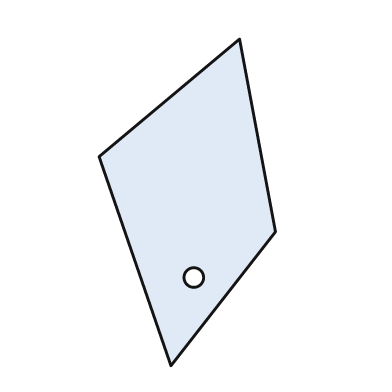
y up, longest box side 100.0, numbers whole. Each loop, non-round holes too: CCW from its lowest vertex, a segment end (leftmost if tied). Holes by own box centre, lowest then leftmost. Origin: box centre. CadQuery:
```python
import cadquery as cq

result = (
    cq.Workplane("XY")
    .moveTo(-5.0, -50.0)
    .lineTo(27.0, -9.0)
    .lineTo(16.0, 50.0)
    .lineTo(-27.0, 14.0)
    .close()
    .moveTo(2.0, -23.0)
    .circle(3.0)
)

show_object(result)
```